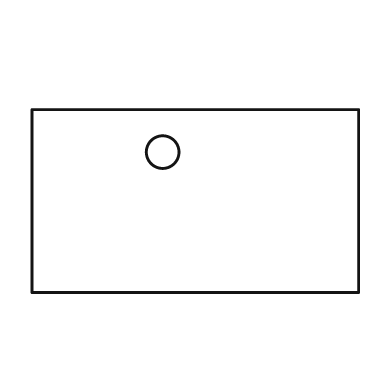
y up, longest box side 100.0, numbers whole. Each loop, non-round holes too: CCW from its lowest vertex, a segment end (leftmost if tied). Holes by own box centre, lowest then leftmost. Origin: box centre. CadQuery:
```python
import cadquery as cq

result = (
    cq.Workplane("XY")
    .moveTo(-50.0, -28.0)
    .lineTo(50.0, -28.0)
    .lineTo(50.0, 28.0)
    .lineTo(-50.0, 28.0)
    .close()
    .moveTo(-10.0, 15.0)
    .circle(5.0)
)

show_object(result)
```